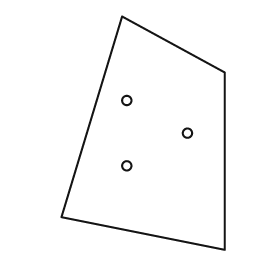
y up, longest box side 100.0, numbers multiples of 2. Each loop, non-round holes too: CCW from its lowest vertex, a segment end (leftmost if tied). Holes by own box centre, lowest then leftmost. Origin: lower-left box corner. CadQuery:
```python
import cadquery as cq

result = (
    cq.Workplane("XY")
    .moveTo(70.0, 0.0)
    .lineTo(70.0, 76.0)
    .lineTo(26.0, 100.0)
    .lineTo(0.0, 14.0)
    .close()
    .moveTo(28.0, 36.0)
    .circle(2.0)
    .moveTo(54.0, 50.0)
    .circle(2.0)
    .moveTo(28.0, 64.0)
    .circle(2.0)
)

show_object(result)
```